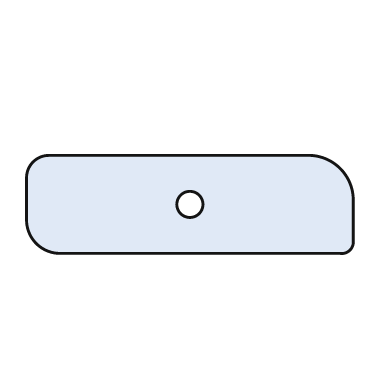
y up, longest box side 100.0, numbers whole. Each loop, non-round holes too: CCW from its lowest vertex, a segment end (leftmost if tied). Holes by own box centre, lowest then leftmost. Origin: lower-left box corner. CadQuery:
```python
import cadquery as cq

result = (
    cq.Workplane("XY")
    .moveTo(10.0, 0.0)
    .lineTo(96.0, 0.0)
    .threePointArc((99.0, 1.0), (100.0, 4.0))
    .lineTo(100.0, 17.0)
    .threePointArc((96.0, 26.0), (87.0, 30.0))
    .lineTo(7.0, 30.0)
    .threePointArc((2.0, 28.0), (0.0, 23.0))
    .lineTo(0.0, 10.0)
    .threePointArc((3.0, 3.0), (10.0, 0.0))
    .close()
    .moveTo(50.0, 15.0)
    .circle(4.0)
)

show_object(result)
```